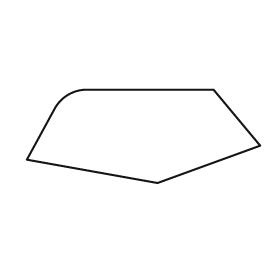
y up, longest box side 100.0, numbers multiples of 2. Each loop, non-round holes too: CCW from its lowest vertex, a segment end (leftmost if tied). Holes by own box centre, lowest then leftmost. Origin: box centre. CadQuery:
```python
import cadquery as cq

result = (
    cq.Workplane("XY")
    .moveTo(6.0, -20.0)
    .lineTo(50.0, -4.0)
    .lineTo(30.0, 20.0)
    .lineTo(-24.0, 20.0)
    .threePointArc((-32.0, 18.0), (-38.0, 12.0))
    .lineTo(-50.0, -10.0)
    .close()
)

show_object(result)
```